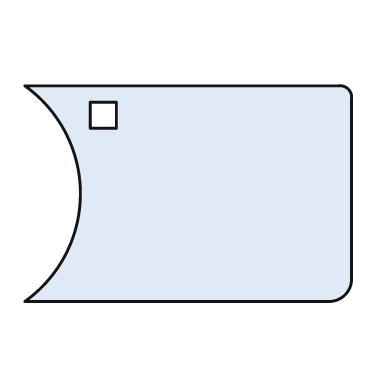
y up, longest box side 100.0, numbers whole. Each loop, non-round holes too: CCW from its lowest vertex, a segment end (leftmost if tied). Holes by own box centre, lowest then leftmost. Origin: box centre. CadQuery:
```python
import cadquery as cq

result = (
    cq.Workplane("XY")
    .moveTo(-50.0, -33.0)
    .lineTo(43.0, -33.0)
    .threePointArc((48.0, -31.0), (50.0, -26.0))
    .lineTo(50.0, 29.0)
    .threePointArc((49.0, 32.0), (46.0, 33.0))
    .lineTo(-50.0, 33.0)
    .threePointArc((-33.0, 0.0), (-50.0, -33.0))
    .close()
    .moveTo(-30.0, 20.0)
    .lineTo(-22.0, 20.0)
    .lineTo(-22.0, 28.0)
    .lineTo(-30.0, 28.0)
    .close()
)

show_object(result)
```